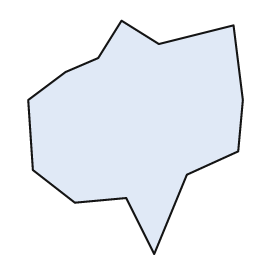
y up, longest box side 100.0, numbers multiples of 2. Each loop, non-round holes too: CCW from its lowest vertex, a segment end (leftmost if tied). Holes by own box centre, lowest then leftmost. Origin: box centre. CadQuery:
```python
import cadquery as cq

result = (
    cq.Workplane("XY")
    .moveTo(8.0, -50.0)
    .lineTo(22.0, -16.0)
    .lineTo(44.0, -6.0)
    .lineTo(46.0, 16.0)
    .lineTo(42.0, 48.0)
    .lineTo(10.0, 40.0)
    .lineTo(-6.0, 50.0)
    .lineTo(-16.0, 34.0)
    .lineTo(-30.0, 28.0)
    .lineTo(-46.0, 16.0)
    .lineTo(-44.0, -14.0)
    .lineTo(-26.0, -28.0)
    .lineTo(-4.0, -26.0)
    .close()
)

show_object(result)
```